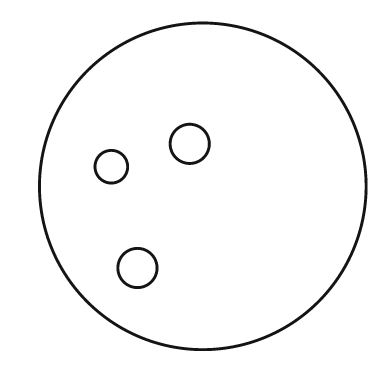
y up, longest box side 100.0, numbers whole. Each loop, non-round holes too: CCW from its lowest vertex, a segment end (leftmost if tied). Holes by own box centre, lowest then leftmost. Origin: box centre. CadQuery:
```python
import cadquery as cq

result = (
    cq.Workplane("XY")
    .moveTo(0.0, 0.0)
    .circle(50.0)
    .moveTo(-20.0, -25.0)
    .circle(6.0)
    .moveTo(-28.0, 6.0)
    .circle(5.0)
    .moveTo(-4.0, 13.0)
    .circle(6.0)
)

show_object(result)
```